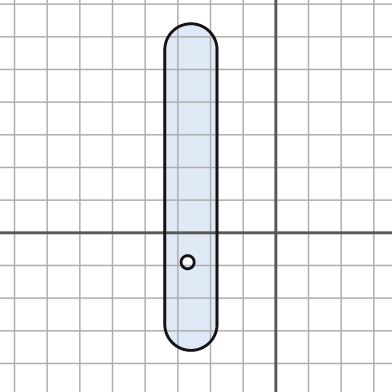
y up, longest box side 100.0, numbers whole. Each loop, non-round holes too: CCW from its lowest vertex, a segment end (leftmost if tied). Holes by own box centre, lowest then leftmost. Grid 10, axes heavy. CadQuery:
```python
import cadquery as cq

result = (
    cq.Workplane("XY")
    .moveTo(-34.0, -28.0)
    .threePointArc((-26.0, -36.0), (-18.0, -28.0))
    .lineTo(-18.0, 56.0)
    .threePointArc((-26.0, 64.0), (-34.0, 56.0))
    .close()
    .moveTo(-27.0, -9.0)
    .circle(2.0)
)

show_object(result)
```